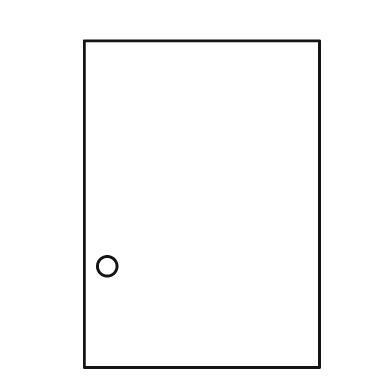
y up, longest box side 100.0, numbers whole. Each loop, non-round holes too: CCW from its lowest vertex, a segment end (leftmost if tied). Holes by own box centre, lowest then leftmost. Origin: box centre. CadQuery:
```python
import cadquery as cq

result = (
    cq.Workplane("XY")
    .moveTo(-36.0, -50.0)
    .lineTo(36.0, -50.0)
    .lineTo(36.0, 50.0)
    .lineTo(-36.0, 50.0)
    .close()
    .moveTo(-29.0, -19.0)
    .circle(3.0)
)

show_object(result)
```